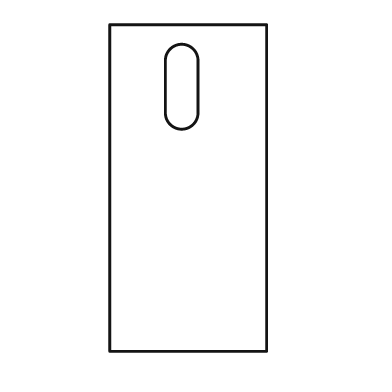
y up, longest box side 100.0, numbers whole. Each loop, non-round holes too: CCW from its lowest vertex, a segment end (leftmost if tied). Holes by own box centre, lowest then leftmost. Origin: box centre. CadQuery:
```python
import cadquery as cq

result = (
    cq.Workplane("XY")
    .moveTo(-24.0, -50.0)
    .lineTo(24.0, -50.0)
    .lineTo(24.0, 50.0)
    .lineTo(-24.0, 50.0)
    .close()
    .moveTo(-7.0, 23.0)
    .threePointArc((-2.0, 18.0), (3.0, 23.0))
    .lineTo(3.0, 39.0)
    .threePointArc((-2.0, 44.0), (-7.0, 39.0))
    .close()
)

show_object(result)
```